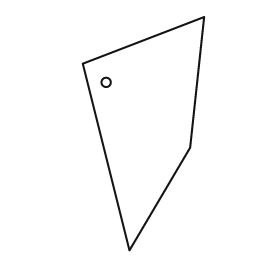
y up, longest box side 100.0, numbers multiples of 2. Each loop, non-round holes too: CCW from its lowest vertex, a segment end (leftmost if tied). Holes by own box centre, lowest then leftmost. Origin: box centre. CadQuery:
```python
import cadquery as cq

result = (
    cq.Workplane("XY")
    .moveTo(-6.0, -50.0)
    .lineTo(20.0, -6.0)
    .lineTo(26.0, 50.0)
    .lineTo(-26.0, 30.0)
    .close()
    .moveTo(-16.0, 22.0)
    .circle(2.0)
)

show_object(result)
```